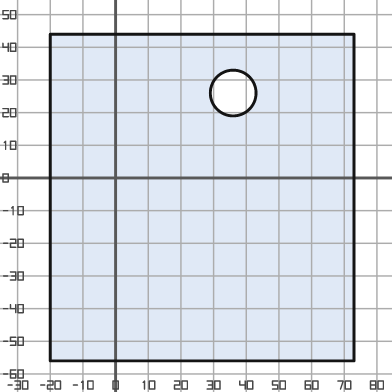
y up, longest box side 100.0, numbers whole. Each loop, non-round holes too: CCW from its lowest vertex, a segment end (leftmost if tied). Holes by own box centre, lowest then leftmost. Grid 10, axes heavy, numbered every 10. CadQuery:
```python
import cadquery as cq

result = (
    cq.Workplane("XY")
    .moveTo(-20.0, -56.0)
    .lineTo(73.0, -56.0)
    .lineTo(73.0, 44.0)
    .lineTo(-20.0, 44.0)
    .close()
    .moveTo(36.0, 26.0)
    .circle(7.0)
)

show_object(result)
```